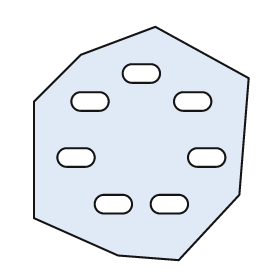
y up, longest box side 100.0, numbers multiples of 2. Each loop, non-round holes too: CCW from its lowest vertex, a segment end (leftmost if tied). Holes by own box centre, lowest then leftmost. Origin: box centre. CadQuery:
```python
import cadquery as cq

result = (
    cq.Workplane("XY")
    .moveTo(16.0, -50.0)
    .lineTo(42.0, -22.0)
    .lineTo(46.0, 28.0)
    .lineTo(6.0, 50.0)
    .lineTo(-26.0, 38.0)
    .lineTo(-46.0, 18.0)
    .lineTo(-46.0, -32.0)
    .lineTo(-10.0, -48.0)
    .close()
    .moveTo(-16.0, -30.0)
    .lineTo(-8.0, -30.0)
    .threePointArc((-4.0, -26.0), (-8.0, -22.0))
    .lineTo(-16.0, -22.0)
    .threePointArc((-20.0, -26.0), (-16.0, -30.0))
    .close()
    .moveTo(8.0, -30.0)
    .lineTo(16.0, -30.0)
    .threePointArc((20.0, -26.0), (16.0, -22.0))
    .lineTo(8.0, -22.0)
    .threePointArc((4.0, -26.0), (8.0, -30.0))
    .close()
    .moveTo(-32.0, -10.0)
    .lineTo(-24.0, -10.0)
    .threePointArc((-20.0, -6.0), (-24.0, -2.0))
    .lineTo(-32.0, -2.0)
    .threePointArc((-36.0, -6.0), (-32.0, -10.0))
    .close()
    .moveTo(24.0, -10.0)
    .lineTo(32.0, -10.0)
    .threePointArc((36.0, -6.0), (32.0, -2.0))
    .lineTo(24.0, -2.0)
    .threePointArc((20.0, -6.0), (24.0, -10.0))
    .close()
    .moveTo(-26.0, 14.0)
    .lineTo(-18.0, 14.0)
    .threePointArc((-14.0, 18.0), (-18.0, 22.0))
    .lineTo(-26.0, 22.0)
    .threePointArc((-30.0, 18.0), (-26.0, 14.0))
    .close()
    .moveTo(18.0, 14.0)
    .lineTo(26.0, 14.0)
    .threePointArc((30.0, 18.0), (26.0, 22.0))
    .lineTo(18.0, 22.0)
    .threePointArc((14.0, 18.0), (18.0, 14.0))
    .close()
    .moveTo(-4.0, 26.0)
    .lineTo(4.0, 26.0)
    .threePointArc((8.0, 30.0), (4.0, 34.0))
    .lineTo(-4.0, 34.0)
    .threePointArc((-8.0, 30.0), (-4.0, 26.0))
    .close()
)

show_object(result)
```